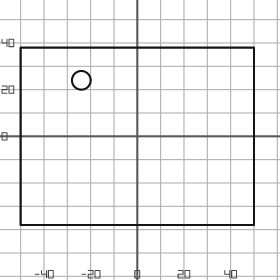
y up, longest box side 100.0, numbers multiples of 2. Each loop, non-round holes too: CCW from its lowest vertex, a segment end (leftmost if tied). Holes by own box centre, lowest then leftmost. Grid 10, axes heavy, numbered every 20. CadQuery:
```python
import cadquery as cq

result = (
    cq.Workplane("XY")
    .moveTo(-50.0, -38.0)
    .lineTo(50.0, -38.0)
    .lineTo(50.0, 38.0)
    .lineTo(-50.0, 38.0)
    .close()
    .moveTo(-24.0, 24.0)
    .circle(4.0)
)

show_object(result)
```